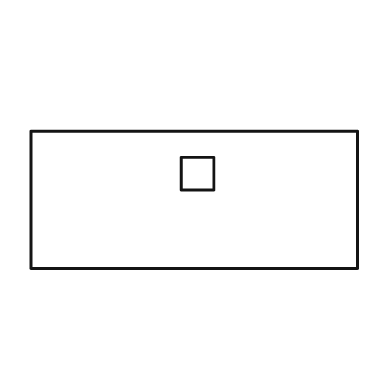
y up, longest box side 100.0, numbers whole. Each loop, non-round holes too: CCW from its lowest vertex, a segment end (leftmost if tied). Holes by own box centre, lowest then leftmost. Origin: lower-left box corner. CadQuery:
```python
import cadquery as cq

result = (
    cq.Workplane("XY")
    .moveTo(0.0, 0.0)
    .lineTo(100.0, 0.0)
    .lineTo(100.0, 42.0)
    .lineTo(0.0, 42.0)
    .close()
    .moveTo(46.0, 24.0)
    .lineTo(56.0, 24.0)
    .lineTo(56.0, 34.0)
    .lineTo(46.0, 34.0)
    .close()
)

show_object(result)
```